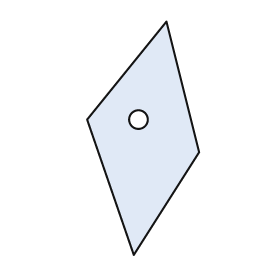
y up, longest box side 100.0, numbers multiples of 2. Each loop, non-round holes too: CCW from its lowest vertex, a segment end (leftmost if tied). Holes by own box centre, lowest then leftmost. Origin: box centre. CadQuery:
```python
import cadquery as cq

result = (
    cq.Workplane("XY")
    .moveTo(-4.0, -50.0)
    .lineTo(24.0, -6.0)
    .lineTo(10.0, 50.0)
    .lineTo(-24.0, 8.0)
    .close()
    .moveTo(-2.0, 8.0)
    .circle(4.0)
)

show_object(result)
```